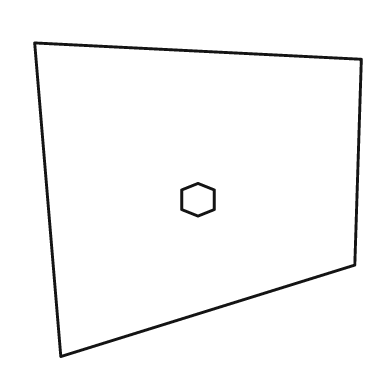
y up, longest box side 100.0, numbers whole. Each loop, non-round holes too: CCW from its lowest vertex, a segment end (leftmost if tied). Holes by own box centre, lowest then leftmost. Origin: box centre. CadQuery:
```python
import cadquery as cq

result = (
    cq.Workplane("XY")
    .moveTo(-42.0, -48.0)
    .lineTo(48.0, -20.0)
    .lineTo(50.0, 43.0)
    .lineTo(-50.0, 48.0)
    .close()
    .moveTo(0.0, -5.0)
    .lineTo(5.0, -3.0)
    .lineTo(5.0, 3.0)
    .lineTo(0.0, 5.0)
    .lineTo(-5.0, 3.0)
    .lineTo(-5.0, -3.0)
    .close()
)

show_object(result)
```